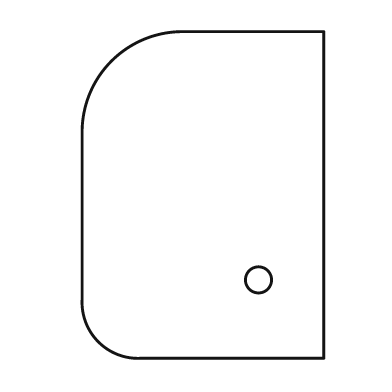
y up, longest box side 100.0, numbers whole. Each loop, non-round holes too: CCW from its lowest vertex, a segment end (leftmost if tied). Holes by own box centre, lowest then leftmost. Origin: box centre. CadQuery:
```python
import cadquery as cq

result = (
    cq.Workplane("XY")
    .moveTo(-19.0, -50.0)
    .lineTo(37.0, -50.0)
    .lineTo(37.0, 50.0)
    .lineTo(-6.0, 50.0)
    .threePointArc((-28.0, 41.0), (-37.0, 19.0))
    .lineTo(-37.0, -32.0)
    .threePointArc((-32.0, -45.0), (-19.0, -50.0))
    .close()
    .moveTo(17.0, -26.0)
    .circle(4.0)
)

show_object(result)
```